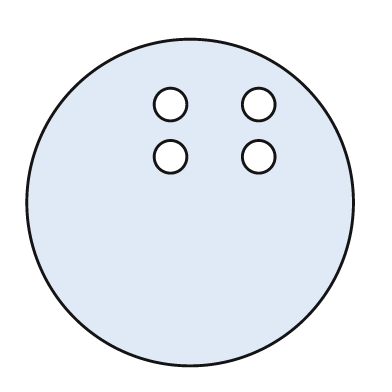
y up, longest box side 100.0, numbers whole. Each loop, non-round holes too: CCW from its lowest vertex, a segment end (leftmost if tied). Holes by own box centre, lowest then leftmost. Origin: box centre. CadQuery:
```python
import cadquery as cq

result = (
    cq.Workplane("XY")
    .moveTo(0.0, 0.0)
    .circle(50.0)
    .moveTo(-6.0, 14.0)
    .circle(5.0)
    .moveTo(21.0, 14.0)
    .circle(5.0)
    .moveTo(-6.0, 30.0)
    .circle(5.0)
    .moveTo(21.0, 30.0)
    .circle(5.0)
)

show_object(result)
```